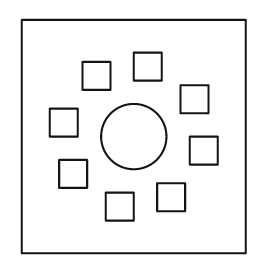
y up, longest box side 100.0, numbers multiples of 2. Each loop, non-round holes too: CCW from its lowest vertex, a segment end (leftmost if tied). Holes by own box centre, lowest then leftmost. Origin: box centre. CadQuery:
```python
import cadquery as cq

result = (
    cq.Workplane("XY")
    .moveTo(-48.0, -50.0)
    .lineTo(48.0, -50.0)
    .lineTo(48.0, 50.0)
    .lineTo(-48.0, 50.0)
    .close()
    .moveTo(-12.0, -36.0)
    .lineTo(0.0, -36.0)
    .lineTo(0.0, -24.0)
    .lineTo(-12.0, -24.0)
    .close()
    .moveTo(10.0, -32.0)
    .lineTo(22.0, -32.0)
    .lineTo(22.0, -20.0)
    .lineTo(10.0, -20.0)
    .close()
    .moveTo(-32.0, -22.0)
    .lineTo(-20.0, -22.0)
    .lineTo(-20.0, -10.0)
    .lineTo(-32.0, -10.0)
    .close()
    .moveTo(24.0, -12.0)
    .lineTo(36.0, -12.0)
    .lineTo(36.0, 0.0)
    .lineTo(24.0, 0.0)
    .close()
    .moveTo(0.0, 0.0)
    .circle(14.0)
    .moveTo(-36.0, 0.0)
    .lineTo(-24.0, 0.0)
    .lineTo(-24.0, 12.0)
    .lineTo(-36.0, 12.0)
    .close()
    .moveTo(20.0, 10.0)
    .lineTo(32.0, 10.0)
    .lineTo(32.0, 22.0)
    .lineTo(20.0, 22.0)
    .close()
    .moveTo(-22.0, 20.0)
    .lineTo(-10.0, 20.0)
    .lineTo(-10.0, 32.0)
    .lineTo(-22.0, 32.0)
    .close()
    .moveTo(0.0, 24.0)
    .lineTo(12.0, 24.0)
    .lineTo(12.0, 36.0)
    .lineTo(0.0, 36.0)
    .close()
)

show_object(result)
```